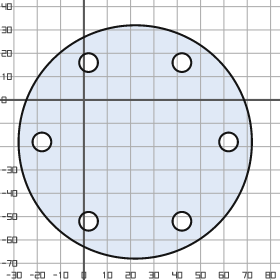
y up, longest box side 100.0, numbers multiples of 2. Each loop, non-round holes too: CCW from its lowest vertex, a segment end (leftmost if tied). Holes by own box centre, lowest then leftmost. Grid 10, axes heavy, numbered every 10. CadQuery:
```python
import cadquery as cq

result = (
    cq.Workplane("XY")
    .moveTo(22.0, -18.0)
    .circle(50.0)
    .moveTo(2.0, -52.0)
    .circle(4.0)
    .moveTo(42.0, -52.0)
    .circle(4.0)
    .moveTo(-18.0, -18.0)
    .circle(4.0)
    .moveTo(62.0, -18.0)
    .circle(4.0)
    .moveTo(2.0, 16.0)
    .circle(4.0)
    .moveTo(42.0, 16.0)
    .circle(4.0)
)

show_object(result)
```